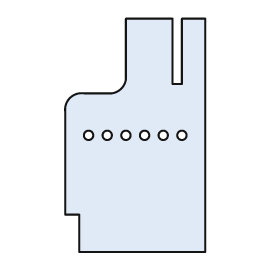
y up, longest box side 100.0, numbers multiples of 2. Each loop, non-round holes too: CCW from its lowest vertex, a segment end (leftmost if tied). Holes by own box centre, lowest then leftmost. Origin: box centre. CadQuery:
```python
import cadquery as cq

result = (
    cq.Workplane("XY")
    .moveTo(-24.0, -50.0)
    .lineTo(30.0, -50.0)
    .lineTo(30.0, 50.0)
    .lineTo(20.0, 50.0)
    .lineTo(20.0, 22.0)
    .lineTo(16.0, 22.0)
    .lineTo(16.0, 50.0)
    .lineTo(-4.0, 50.0)
    .lineTo(-4.0, 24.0)
    .threePointArc((-6.0, 20.0), (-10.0, 18.0))
    .lineTo(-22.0, 18.0)
    .threePointArc((-28.0, 16.0), (-30.0, 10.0))
    .lineTo(-30.0, -34.0)
    .lineTo(-24.0, -34.0)
    .close()
    .moveTo(-20.0, 0.0)
    .circle(2.0)
    .moveTo(-12.0, 0.0)
    .circle(2.0)
    .moveTo(-4.0, 0.0)
    .circle(2.0)
    .moveTo(4.0, 0.0)
    .circle(2.0)
    .moveTo(12.0, 0.0)
    .circle(2.0)
    .moveTo(20.0, 0.0)
    .circle(2.0)
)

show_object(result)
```